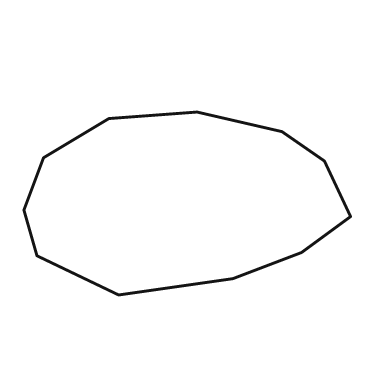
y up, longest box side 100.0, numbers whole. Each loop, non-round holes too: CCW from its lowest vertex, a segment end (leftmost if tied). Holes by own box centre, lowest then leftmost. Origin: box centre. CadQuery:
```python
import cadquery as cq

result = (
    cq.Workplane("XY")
    .moveTo(-21.0, -28.0)
    .lineTo(14.0, -23.0)
    .lineTo(35.0, -15.0)
    .lineTo(50.0, -4.0)
    .lineTo(42.0, 13.0)
    .lineTo(29.0, 22.0)
    .lineTo(3.0, 28.0)
    .lineTo(-24.0, 26.0)
    .lineTo(-44.0, 14.0)
    .lineTo(-50.0, -2.0)
    .lineTo(-46.0, -16.0)
    .close()
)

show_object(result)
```